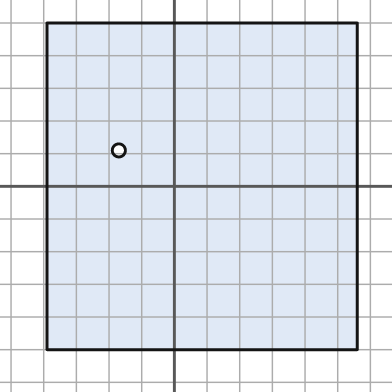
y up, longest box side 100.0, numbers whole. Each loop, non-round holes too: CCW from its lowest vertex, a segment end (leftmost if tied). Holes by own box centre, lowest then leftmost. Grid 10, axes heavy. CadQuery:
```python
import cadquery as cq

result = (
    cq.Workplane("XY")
    .moveTo(-39.0, -50.0)
    .lineTo(56.0, -50.0)
    .lineTo(56.0, 50.0)
    .lineTo(-39.0, 50.0)
    .close()
    .moveTo(-17.0, 11.0)
    .circle(2.0)
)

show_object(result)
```